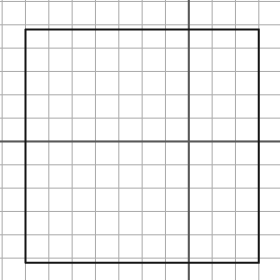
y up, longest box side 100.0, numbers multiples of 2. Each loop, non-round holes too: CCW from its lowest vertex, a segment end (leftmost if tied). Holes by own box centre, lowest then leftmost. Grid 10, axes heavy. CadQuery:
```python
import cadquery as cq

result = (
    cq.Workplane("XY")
    .moveTo(-70.0, -52.0)
    .lineTo(30.0, -52.0)
    .lineTo(30.0, 48.0)
    .lineTo(-70.0, 48.0)
    .close()
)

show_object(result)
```